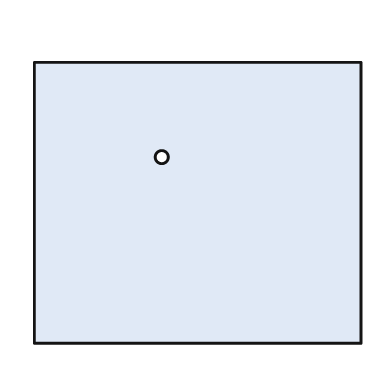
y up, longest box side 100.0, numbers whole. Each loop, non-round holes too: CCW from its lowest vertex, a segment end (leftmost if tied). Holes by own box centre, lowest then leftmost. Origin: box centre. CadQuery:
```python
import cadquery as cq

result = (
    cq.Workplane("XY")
    .moveTo(-50.0, -43.0)
    .lineTo(50.0, -43.0)
    .lineTo(50.0, 43.0)
    .lineTo(-50.0, 43.0)
    .close()
    .moveTo(-11.0, 14.0)
    .circle(2.0)
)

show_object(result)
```